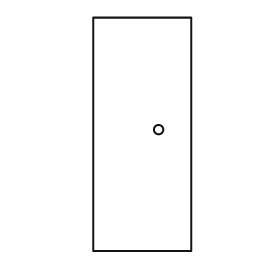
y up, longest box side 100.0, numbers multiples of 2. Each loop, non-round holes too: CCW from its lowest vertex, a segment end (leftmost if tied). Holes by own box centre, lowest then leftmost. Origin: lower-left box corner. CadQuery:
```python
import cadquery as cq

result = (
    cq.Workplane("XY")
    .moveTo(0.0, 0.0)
    .lineTo(42.0, 0.0)
    .lineTo(42.0, 100.0)
    .lineTo(0.0, 100.0)
    .close()
    .moveTo(28.0, 52.0)
    .circle(2.0)
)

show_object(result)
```